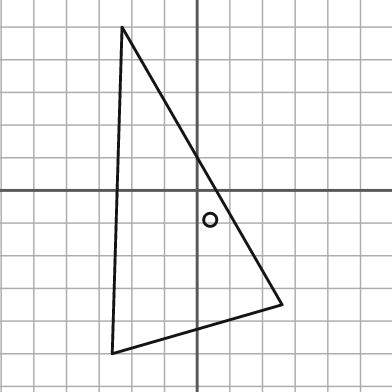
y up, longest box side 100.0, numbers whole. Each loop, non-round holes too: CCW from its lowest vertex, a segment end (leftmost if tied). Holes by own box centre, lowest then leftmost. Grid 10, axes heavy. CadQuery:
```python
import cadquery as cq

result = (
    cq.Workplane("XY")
    .moveTo(-26.0, -50.0)
    .lineTo(26.0, -35.0)
    .lineTo(-23.0, 50.0)
    .close()
    .moveTo(4.0, -9.0)
    .circle(2.0)
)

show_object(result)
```